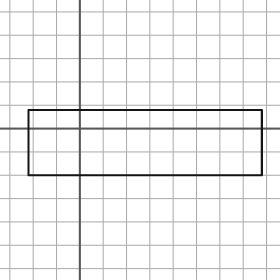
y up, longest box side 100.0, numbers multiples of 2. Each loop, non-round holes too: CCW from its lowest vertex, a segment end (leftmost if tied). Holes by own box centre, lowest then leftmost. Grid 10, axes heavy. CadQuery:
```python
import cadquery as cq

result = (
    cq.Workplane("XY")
    .moveTo(-22.0, -20.0)
    .lineTo(78.0, -20.0)
    .lineTo(78.0, 8.0)
    .lineTo(-22.0, 8.0)
    .close()
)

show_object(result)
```